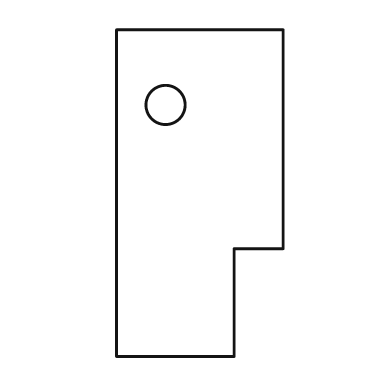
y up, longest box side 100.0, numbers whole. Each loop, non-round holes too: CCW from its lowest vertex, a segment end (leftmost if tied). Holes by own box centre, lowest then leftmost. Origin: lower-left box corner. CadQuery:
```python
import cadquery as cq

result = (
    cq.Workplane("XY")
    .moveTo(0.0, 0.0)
    .lineTo(36.0, 0.0)
    .lineTo(36.0, 33.0)
    .lineTo(51.0, 33.0)
    .lineTo(51.0, 100.0)
    .lineTo(0.0, 100.0)
    .close()
    .moveTo(15.0, 77.0)
    .circle(6.0)
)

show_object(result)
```